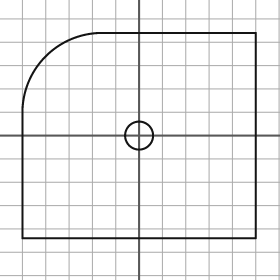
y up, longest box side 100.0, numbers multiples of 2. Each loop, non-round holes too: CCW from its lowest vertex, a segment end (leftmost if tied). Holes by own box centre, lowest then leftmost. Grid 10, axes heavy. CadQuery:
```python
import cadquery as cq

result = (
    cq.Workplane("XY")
    .moveTo(-50.0, -44.0)
    .lineTo(50.0, -44.0)
    .lineTo(50.0, 44.0)
    .lineTo(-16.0, 44.0)
    .threePointArc((-40.0, 34.0), (-50.0, 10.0))
    .close()
    .moveTo(0.0, 0.0)
    .circle(6.0)
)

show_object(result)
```